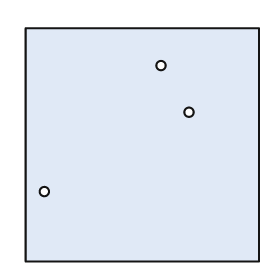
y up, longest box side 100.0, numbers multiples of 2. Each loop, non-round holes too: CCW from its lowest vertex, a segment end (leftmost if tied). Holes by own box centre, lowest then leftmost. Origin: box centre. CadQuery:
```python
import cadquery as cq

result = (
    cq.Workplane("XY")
    .moveTo(-50.0, -50.0)
    .lineTo(50.0, -50.0)
    .lineTo(50.0, 50.0)
    .lineTo(-50.0, 50.0)
    .close()
    .moveTo(-42.0, -20.0)
    .circle(2.0)
    .moveTo(20.0, 14.0)
    .circle(2.0)
    .moveTo(8.0, 34.0)
    .circle(2.0)
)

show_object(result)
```